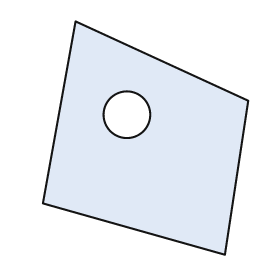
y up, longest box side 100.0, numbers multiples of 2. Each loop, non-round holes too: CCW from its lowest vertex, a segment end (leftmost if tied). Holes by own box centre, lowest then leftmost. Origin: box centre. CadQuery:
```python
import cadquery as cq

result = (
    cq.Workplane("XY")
    .moveTo(34.0, -50.0)
    .lineTo(44.0, 16.0)
    .lineTo(-30.0, 50.0)
    .lineTo(-44.0, -28.0)
    .close()
    .moveTo(-8.0, 10.0)
    .circle(10.0)
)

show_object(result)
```